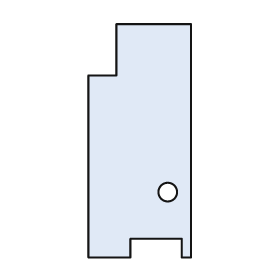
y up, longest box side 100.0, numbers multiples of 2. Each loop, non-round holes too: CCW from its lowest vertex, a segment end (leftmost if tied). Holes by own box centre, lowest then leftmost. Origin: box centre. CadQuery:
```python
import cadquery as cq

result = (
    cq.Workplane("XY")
    .moveTo(-22.0, -50.0)
    .lineTo(-4.0, -50.0)
    .lineTo(-4.0, -42.0)
    .lineTo(18.0, -42.0)
    .lineTo(18.0, -50.0)
    .lineTo(22.0, -50.0)
    .lineTo(22.0, 50.0)
    .lineTo(-10.0, 50.0)
    .lineTo(-10.0, 28.0)
    .lineTo(-22.0, 28.0)
    .close()
    .moveTo(12.0, -22.0)
    .circle(4.0)
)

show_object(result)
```